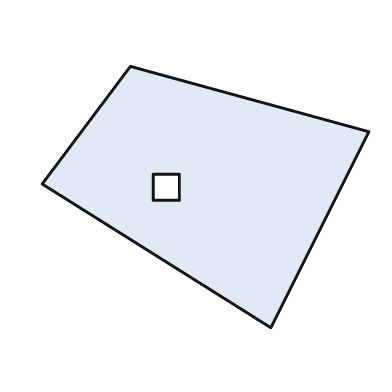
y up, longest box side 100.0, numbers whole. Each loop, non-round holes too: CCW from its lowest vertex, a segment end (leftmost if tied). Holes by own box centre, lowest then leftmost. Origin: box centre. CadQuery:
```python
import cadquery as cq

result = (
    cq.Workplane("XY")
    .moveTo(20.0, -40.0)
    .lineTo(50.0, 20.0)
    .lineTo(-23.0, 40.0)
    .lineTo(-50.0, 4.0)
    .close()
    .moveTo(-16.0, -1.0)
    .lineTo(-8.0, -1.0)
    .lineTo(-8.0, 7.0)
    .lineTo(-16.0, 7.0)
    .close()
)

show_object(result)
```